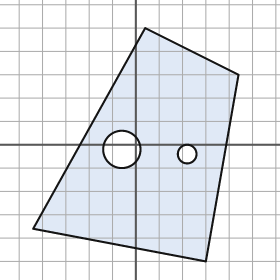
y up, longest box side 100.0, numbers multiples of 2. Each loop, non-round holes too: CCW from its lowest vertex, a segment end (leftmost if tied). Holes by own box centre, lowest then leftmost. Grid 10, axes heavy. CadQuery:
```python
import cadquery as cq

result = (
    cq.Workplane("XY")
    .moveTo(30.0, -50.0)
    .lineTo(44.0, 30.0)
    .lineTo(4.0, 50.0)
    .lineTo(-44.0, -36.0)
    .close()
    .moveTo(22.0, -4.0)
    .circle(4.0)
    .moveTo(-6.0, -2.0)
    .circle(8.0)
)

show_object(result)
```